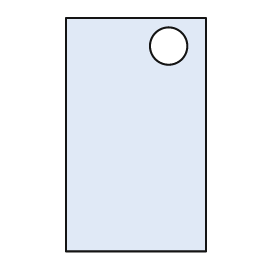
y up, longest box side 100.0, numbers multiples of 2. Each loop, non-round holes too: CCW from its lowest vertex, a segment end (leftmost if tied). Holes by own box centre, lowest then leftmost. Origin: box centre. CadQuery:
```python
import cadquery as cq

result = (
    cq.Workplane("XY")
    .moveTo(-30.0, -50.0)
    .lineTo(30.0, -50.0)
    .lineTo(30.0, 50.0)
    .lineTo(-30.0, 50.0)
    .close()
    .moveTo(14.0, 38.0)
    .circle(8.0)
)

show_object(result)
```